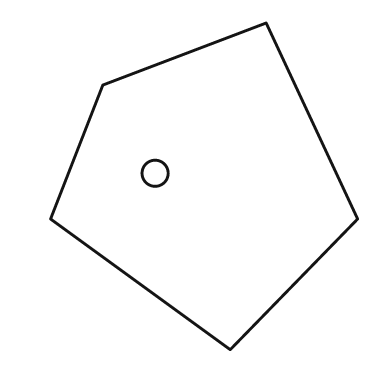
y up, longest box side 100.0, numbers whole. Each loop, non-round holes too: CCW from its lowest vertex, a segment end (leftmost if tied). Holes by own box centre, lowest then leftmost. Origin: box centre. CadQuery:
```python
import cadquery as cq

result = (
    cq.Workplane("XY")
    .moveTo(8.0, -50.0)
    .lineTo(47.0, -10.0)
    .lineTo(19.0, 50.0)
    .lineTo(-31.0, 31.0)
    .lineTo(-47.0, -10.0)
    .close()
    .moveTo(-15.0, 4.0)
    .circle(4.0)
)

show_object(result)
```